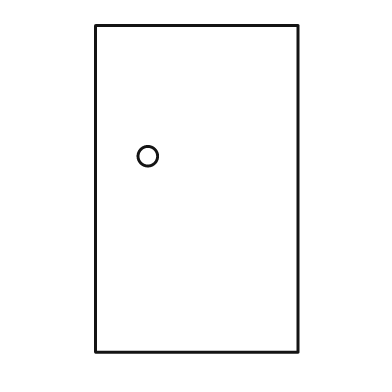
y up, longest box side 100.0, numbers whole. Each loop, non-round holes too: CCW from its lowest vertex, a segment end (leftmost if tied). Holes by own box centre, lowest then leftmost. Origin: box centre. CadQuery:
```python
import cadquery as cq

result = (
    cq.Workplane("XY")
    .moveTo(-31.0, -50.0)
    .lineTo(31.0, -50.0)
    .lineTo(31.0, 50.0)
    .lineTo(-31.0, 50.0)
    .close()
    .moveTo(-15.0, 10.0)
    .circle(3.0)
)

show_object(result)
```